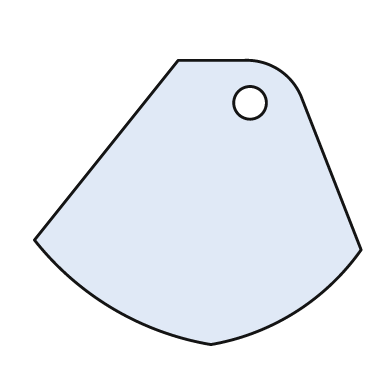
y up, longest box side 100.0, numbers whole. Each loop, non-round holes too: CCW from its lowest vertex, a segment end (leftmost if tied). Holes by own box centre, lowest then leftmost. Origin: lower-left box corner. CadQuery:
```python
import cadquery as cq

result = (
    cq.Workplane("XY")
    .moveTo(54.0, 0.0)
    .threePointArc((80.0, 10.0), (100.0, 29.0))
    .lineTo(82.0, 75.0)
    .threePointArc((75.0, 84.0), (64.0, 87.0))
    .lineTo(44.0, 87.0)
    .lineTo(0.0, 32.0)
    .threePointArc((24.0, 11.0), (54.0, 0.0))
    .close()
    .moveTo(66.0, 74.0)
    .circle(5.0)
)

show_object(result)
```